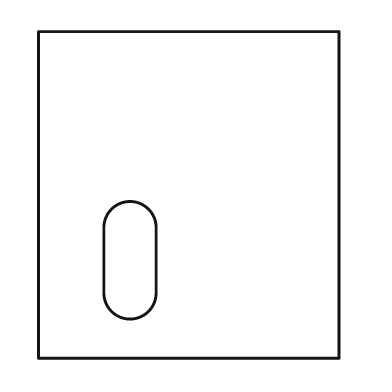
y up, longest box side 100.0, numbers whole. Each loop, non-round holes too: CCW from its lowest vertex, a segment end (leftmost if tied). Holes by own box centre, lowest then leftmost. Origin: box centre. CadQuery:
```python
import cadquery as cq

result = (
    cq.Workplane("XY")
    .moveTo(-46.0, -50.0)
    .lineTo(46.0, -50.0)
    .lineTo(46.0, 50.0)
    .lineTo(-46.0, 50.0)
    .close()
    .moveTo(-26.0, -30.0)
    .threePointArc((-18.0, -38.0), (-10.0, -30.0))
    .lineTo(-10.0, -10.0)
    .threePointArc((-18.0, -2.0), (-26.0, -10.0))
    .close()
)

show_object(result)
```